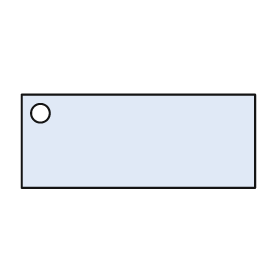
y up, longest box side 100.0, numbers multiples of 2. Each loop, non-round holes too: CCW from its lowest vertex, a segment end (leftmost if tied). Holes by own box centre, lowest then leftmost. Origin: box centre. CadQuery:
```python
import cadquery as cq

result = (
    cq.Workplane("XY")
    .moveTo(-50.0, -20.0)
    .lineTo(50.0, -20.0)
    .lineTo(50.0, 20.0)
    .lineTo(-50.0, 20.0)
    .close()
    .moveTo(-42.0, 12.0)
    .circle(4.0)
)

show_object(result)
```